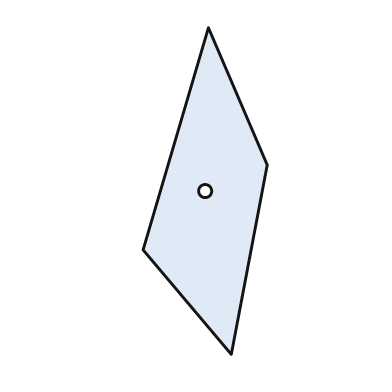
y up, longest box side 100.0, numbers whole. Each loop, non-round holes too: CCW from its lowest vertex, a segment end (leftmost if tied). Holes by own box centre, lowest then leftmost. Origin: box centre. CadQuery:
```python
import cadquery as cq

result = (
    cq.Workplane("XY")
    .moveTo(8.0, -50.0)
    .lineTo(19.0, 8.0)
    .lineTo(1.0, 50.0)
    .lineTo(-19.0, -18.0)
    .close()
    .moveTo(0.0, 0.0)
    .circle(2.0)
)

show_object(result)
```